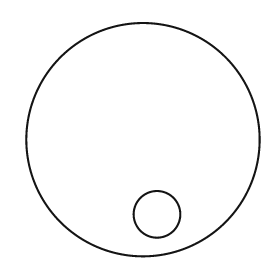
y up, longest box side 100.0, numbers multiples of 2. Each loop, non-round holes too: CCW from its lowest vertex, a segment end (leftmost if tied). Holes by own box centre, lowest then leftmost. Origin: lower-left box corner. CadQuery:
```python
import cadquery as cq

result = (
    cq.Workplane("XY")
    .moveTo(50.0, 50.0)
    .circle(50.0)
    .moveTo(56.0, 18.0)
    .circle(10.0)
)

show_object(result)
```